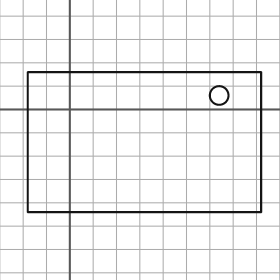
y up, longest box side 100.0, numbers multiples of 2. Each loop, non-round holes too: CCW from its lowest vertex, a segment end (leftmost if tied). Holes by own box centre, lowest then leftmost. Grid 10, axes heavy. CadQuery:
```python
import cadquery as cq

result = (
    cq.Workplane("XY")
    .moveTo(-18.0, -44.0)
    .lineTo(82.0, -44.0)
    .lineTo(82.0, 16.0)
    .lineTo(-18.0, 16.0)
    .close()
    .moveTo(64.0, 6.0)
    .circle(4.0)
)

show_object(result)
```